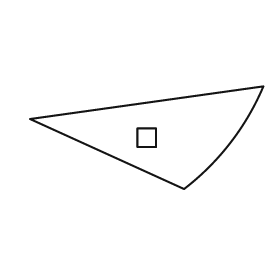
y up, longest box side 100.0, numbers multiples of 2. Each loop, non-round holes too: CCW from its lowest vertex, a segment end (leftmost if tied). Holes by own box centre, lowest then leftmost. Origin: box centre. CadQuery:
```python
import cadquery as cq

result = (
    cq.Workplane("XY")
    .moveTo(16.0, -22.0)
    .threePointArc((36.0, -2.0), (50.0, 22.0))
    .lineTo(-50.0, 8.0)
    .close()
    .moveTo(-4.0, -4.0)
    .lineTo(4.0, -4.0)
    .lineTo(4.0, 4.0)
    .lineTo(-4.0, 4.0)
    .close()
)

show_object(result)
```